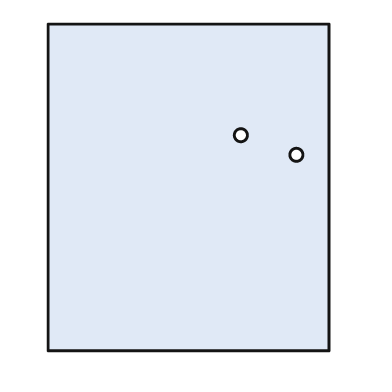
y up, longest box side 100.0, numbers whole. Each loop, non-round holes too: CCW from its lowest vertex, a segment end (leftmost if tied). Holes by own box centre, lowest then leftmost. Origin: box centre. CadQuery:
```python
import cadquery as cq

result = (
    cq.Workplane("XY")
    .moveTo(-43.0, -50.0)
    .lineTo(43.0, -50.0)
    .lineTo(43.0, 50.0)
    .lineTo(-43.0, 50.0)
    .close()
    .moveTo(33.0, 10.0)
    .circle(2.0)
    .moveTo(16.0, 16.0)
    .circle(2.0)
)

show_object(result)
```